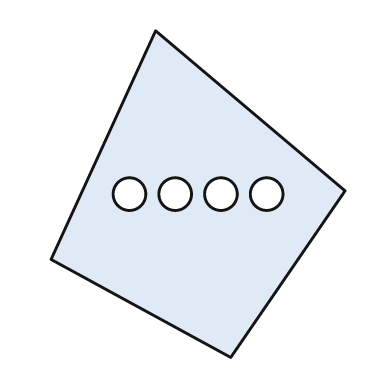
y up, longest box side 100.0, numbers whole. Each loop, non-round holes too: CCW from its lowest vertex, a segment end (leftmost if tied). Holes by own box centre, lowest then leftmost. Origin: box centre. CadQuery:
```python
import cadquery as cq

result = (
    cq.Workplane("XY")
    .moveTo(10.0, -50.0)
    .lineTo(45.0, 1.0)
    .lineTo(-13.0, 50.0)
    .lineTo(-45.0, -20.0)
    .close()
    .moveTo(-21.0, 0.0)
    .circle(5.0)
    .moveTo(-7.0, 0.0)
    .circle(5.0)
    .moveTo(7.0, 0.0)
    .circle(5.0)
    .moveTo(21.0, 0.0)
    .circle(5.0)
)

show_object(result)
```